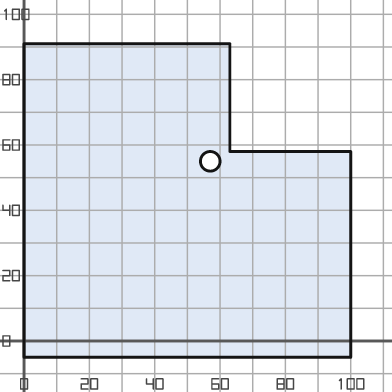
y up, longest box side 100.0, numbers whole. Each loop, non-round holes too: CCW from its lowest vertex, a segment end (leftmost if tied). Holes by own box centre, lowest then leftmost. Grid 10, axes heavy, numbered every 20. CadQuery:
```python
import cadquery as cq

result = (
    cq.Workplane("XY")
    .moveTo(0.0, -5.0)
    .lineTo(100.0, -5.0)
    .lineTo(100.0, 58.0)
    .lineTo(63.0, 58.0)
    .lineTo(63.0, 91.0)
    .lineTo(0.0, 91.0)
    .close()
    .moveTo(57.0, 55.0)
    .circle(3.0)
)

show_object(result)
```